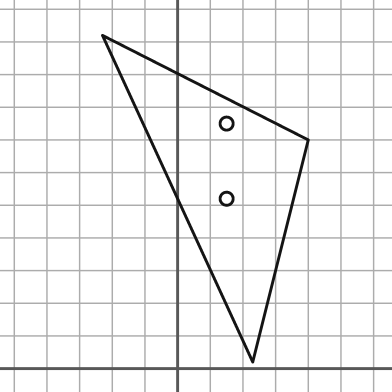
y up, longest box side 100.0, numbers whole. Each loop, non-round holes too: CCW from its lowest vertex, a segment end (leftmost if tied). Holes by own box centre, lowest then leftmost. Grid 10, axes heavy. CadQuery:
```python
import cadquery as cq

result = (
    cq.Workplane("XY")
    .moveTo(23.0, 2.0)
    .lineTo(40.0, 70.0)
    .lineTo(-23.0, 102.0)
    .close()
    .moveTo(15.0, 52.0)
    .circle(2.0)
    .moveTo(15.0, 75.0)
    .circle(2.0)
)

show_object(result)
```